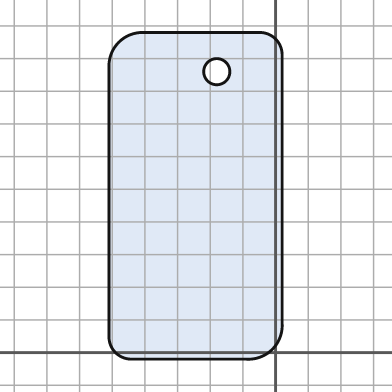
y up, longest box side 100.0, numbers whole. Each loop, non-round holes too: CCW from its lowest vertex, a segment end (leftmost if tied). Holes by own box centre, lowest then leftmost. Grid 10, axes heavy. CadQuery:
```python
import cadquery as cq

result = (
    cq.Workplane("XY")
    .moveTo(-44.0, -2.0)
    .lineTo(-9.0, -2.0)
    .threePointArc((-1.0, 1.0), (2.0, 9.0))
    .lineTo(2.0, 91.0)
    .threePointArc((0.0, 96.0), (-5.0, 98.0))
    .lineTo(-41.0, 98.0)
    .threePointArc((-48.0, 95.0), (-51.0, 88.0))
    .lineTo(-51.0, 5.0)
    .threePointArc((-49.0, 0.0), (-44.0, -2.0))
    .close()
    .moveTo(-18.0, 86.0)
    .circle(4.0)
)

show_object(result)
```